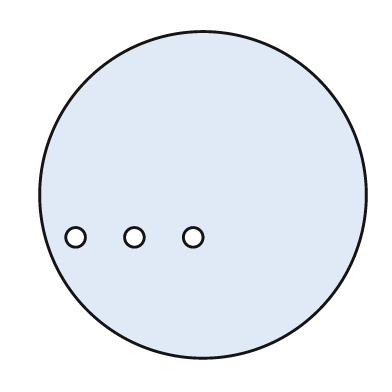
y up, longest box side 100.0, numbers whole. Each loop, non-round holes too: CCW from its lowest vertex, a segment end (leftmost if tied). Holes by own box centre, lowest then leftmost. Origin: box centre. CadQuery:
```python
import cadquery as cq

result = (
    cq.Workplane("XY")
    .moveTo(0.0, 0.0)
    .circle(50.0)
    .moveTo(-39.0, -13.0)
    .circle(3.0)
    .moveTo(-21.0, -13.0)
    .circle(3.0)
    .moveTo(-3.0, -13.0)
    .circle(3.0)
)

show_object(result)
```